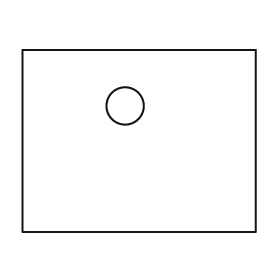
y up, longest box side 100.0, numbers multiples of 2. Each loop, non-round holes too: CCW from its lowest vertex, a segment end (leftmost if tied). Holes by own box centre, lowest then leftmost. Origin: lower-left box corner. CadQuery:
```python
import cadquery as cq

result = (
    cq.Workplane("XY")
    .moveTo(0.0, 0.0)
    .lineTo(100.0, 0.0)
    .lineTo(100.0, 78.0)
    .lineTo(0.0, 78.0)
    .close()
    .moveTo(44.0, 54.0)
    .circle(8.0)
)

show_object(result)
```